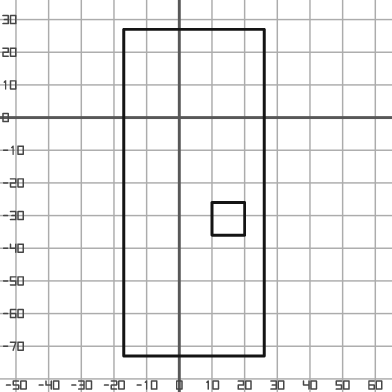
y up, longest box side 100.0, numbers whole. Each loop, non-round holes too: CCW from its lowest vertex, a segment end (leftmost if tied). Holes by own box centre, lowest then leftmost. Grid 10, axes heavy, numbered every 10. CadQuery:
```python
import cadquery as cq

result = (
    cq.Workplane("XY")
    .moveTo(-17.0, -73.0)
    .lineTo(26.0, -73.0)
    .lineTo(26.0, 27.0)
    .lineTo(-17.0, 27.0)
    .close()
    .moveTo(10.0, -36.0)
    .lineTo(20.0, -36.0)
    .lineTo(20.0, -26.0)
    .lineTo(10.0, -26.0)
    .close()
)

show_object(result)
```